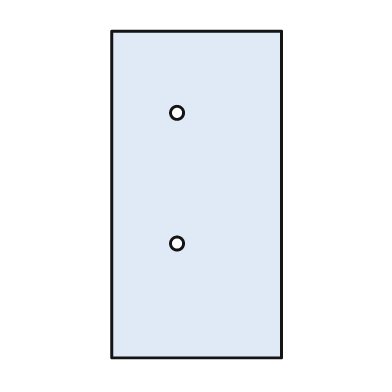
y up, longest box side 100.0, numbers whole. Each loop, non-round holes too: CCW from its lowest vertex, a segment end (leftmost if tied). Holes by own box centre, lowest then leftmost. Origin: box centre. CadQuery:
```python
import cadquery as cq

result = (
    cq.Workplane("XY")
    .moveTo(-26.0, -50.0)
    .lineTo(26.0, -50.0)
    .lineTo(26.0, 50.0)
    .lineTo(-26.0, 50.0)
    .close()
    .moveTo(-6.0, -15.0)
    .circle(2.0)
    .moveTo(-6.0, 25.0)
    .circle(2.0)
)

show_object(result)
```